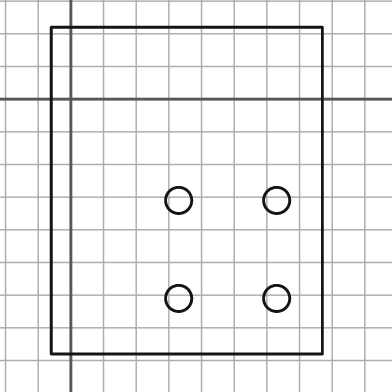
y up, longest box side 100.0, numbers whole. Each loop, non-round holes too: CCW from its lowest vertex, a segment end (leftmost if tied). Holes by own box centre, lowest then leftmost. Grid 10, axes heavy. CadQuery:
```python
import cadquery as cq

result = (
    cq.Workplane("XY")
    .moveTo(-6.0, -78.0)
    .lineTo(77.0, -78.0)
    .lineTo(77.0, 22.0)
    .lineTo(-6.0, 22.0)
    .close()
    .moveTo(33.0, -61.0)
    .circle(4.0)
    .moveTo(63.0, -61.0)
    .circle(4.0)
    .moveTo(33.0, -31.0)
    .circle(4.0)
    .moveTo(63.0, -31.0)
    .circle(4.0)
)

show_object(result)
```